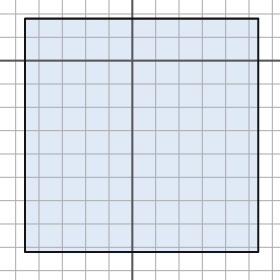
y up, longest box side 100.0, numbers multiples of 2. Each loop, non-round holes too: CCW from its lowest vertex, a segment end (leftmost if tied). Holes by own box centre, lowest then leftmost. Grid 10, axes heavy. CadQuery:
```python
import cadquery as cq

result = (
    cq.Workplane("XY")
    .moveTo(-46.0, -82.0)
    .lineTo(54.0, -82.0)
    .lineTo(54.0, 18.0)
    .lineTo(-46.0, 18.0)
    .close()
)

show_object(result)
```